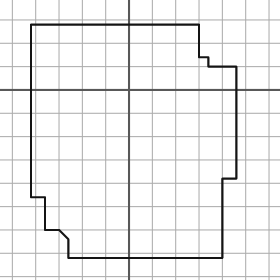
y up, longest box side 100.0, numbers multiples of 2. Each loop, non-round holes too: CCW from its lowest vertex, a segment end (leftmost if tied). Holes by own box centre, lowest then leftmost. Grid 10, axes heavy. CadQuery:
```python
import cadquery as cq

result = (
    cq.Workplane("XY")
    .moveTo(-26.0, -72.0)
    .lineTo(40.0, -72.0)
    .lineTo(40.0, -38.0)
    .lineTo(46.0, -38.0)
    .lineTo(46.0, 10.0)
    .lineTo(34.0, 10.0)
    .lineTo(34.0, 14.0)
    .lineTo(30.0, 14.0)
    .lineTo(30.0, 28.0)
    .lineTo(-42.0, 28.0)
    .lineTo(-42.0, -46.0)
    .lineTo(-36.0, -46.0)
    .lineTo(-36.0, -60.0)
    .lineTo(-30.0, -60.0)
    .lineTo(-26.0, -64.0)
    .close()
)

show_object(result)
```